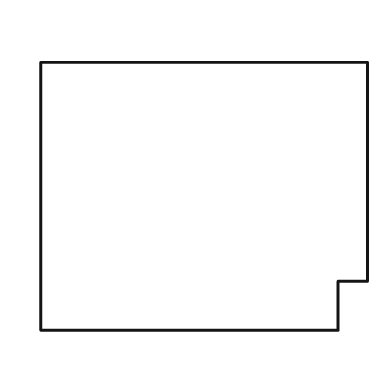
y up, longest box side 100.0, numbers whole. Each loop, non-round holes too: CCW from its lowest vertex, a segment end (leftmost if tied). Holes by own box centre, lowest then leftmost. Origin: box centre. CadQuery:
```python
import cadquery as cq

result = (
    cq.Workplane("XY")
    .moveTo(-50.0, -41.0)
    .lineTo(41.0, -41.0)
    .lineTo(41.0, -26.0)
    .lineTo(50.0, -26.0)
    .lineTo(50.0, 41.0)
    .lineTo(-50.0, 41.0)
    .close()
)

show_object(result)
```